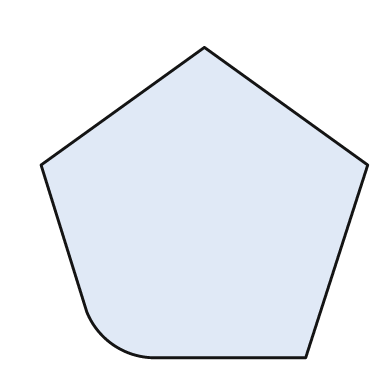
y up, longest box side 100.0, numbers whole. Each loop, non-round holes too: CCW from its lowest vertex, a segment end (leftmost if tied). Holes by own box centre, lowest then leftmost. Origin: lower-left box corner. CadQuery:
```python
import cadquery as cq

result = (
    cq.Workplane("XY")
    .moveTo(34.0, 0.0)
    .lineTo(81.0, 0.0)
    .lineTo(100.0, 59.0)
    .lineTo(50.0, 95.0)
    .lineTo(0.0, 59.0)
    .lineTo(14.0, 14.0)
    .threePointArc((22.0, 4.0), (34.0, 0.0))
    .close()
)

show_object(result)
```